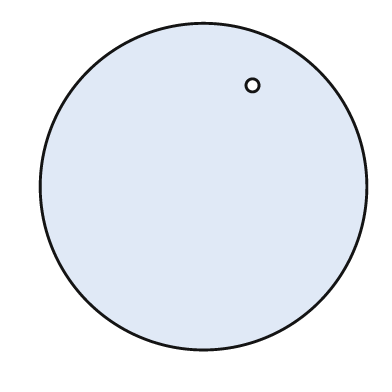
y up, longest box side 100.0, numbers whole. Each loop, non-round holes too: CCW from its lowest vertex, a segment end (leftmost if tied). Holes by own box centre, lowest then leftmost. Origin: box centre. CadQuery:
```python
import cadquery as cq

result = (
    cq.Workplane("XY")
    .moveTo(0.0, 0.0)
    .circle(50.0)
    .moveTo(15.0, 31.0)
    .circle(2.0)
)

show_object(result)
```